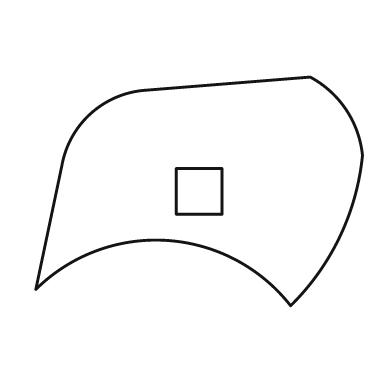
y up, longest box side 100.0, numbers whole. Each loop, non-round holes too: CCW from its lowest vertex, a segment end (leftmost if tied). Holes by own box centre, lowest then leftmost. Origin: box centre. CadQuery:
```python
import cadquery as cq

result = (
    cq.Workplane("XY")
    .moveTo(28.0, -35.0)
    .threePointArc((43.0, -14.0), (50.0, 11.0))
    .threePointArc((45.0, 25.0), (34.0, 35.0))
    .lineTo(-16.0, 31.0)
    .threePointArc((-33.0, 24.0), (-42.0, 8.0))
    .lineTo(-50.0, -30.0)
    .threePointArc((-10.0, -15.0), (28.0, -35.0))
    .close()
    .moveTo(-7.0, -7.0)
    .lineTo(7.0, -7.0)
    .lineTo(7.0, 7.0)
    .lineTo(-7.0, 7.0)
    .close()
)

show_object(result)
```